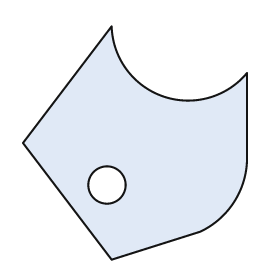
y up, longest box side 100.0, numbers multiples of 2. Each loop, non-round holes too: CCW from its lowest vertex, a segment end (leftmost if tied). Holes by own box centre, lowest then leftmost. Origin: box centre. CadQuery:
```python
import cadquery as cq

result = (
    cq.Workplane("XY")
    .moveTo(-10.0, -50.0)
    .lineTo(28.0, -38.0)
    .threePointArc((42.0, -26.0), (48.0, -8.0))
    .lineTo(48.0, 30.0)
    .threePointArc((12.0, 20.0), (-10.0, 50.0))
    .lineTo(-48.0, 0.0)
    .close()
    .moveTo(-12.0, -18.0)
    .circle(8.0)
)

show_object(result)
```